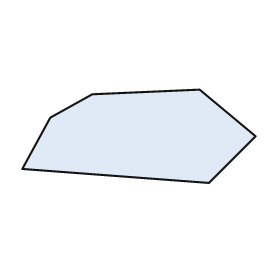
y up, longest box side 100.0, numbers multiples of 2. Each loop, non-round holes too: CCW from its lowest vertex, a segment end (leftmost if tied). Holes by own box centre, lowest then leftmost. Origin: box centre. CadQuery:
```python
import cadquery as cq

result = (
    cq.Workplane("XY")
    .moveTo(30.0, -20.0)
    .lineTo(50.0, 0.0)
    .lineTo(26.0, 20.0)
    .lineTo(-20.0, 18.0)
    .lineTo(-38.0, 8.0)
    .lineTo(-50.0, -14.0)
    .close()
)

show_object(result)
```